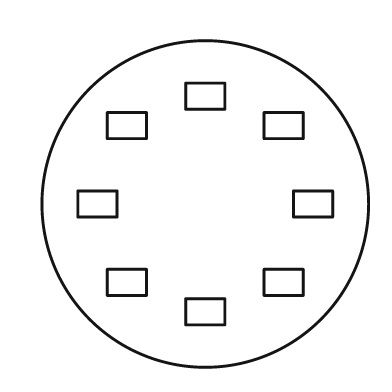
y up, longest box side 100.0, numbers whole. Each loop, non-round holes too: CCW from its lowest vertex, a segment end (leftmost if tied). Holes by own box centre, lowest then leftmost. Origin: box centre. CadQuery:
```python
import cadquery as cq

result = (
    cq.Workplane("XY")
    .moveTo(0.0, 0.0)
    .circle(50.0)
    .moveTo(-6.0, -37.0)
    .lineTo(6.0, -37.0)
    .lineTo(6.0, -29.0)
    .lineTo(-6.0, -29.0)
    .close()
    .moveTo(-30.0, -28.0)
    .lineTo(-18.0, -28.0)
    .lineTo(-18.0, -20.0)
    .lineTo(-30.0, -20.0)
    .close()
    .moveTo(18.0, -28.0)
    .lineTo(30.0, -28.0)
    .lineTo(30.0, -20.0)
    .lineTo(18.0, -20.0)
    .close()
    .moveTo(-39.0, -4.0)
    .lineTo(-27.0, -4.0)
    .lineTo(-27.0, 4.0)
    .lineTo(-39.0, 4.0)
    .close()
    .moveTo(27.0, -4.0)
    .lineTo(39.0, -4.0)
    .lineTo(39.0, 4.0)
    .lineTo(27.0, 4.0)
    .close()
    .moveTo(-30.0, 20.0)
    .lineTo(-18.0, 20.0)
    .lineTo(-18.0, 28.0)
    .lineTo(-30.0, 28.0)
    .close()
    .moveTo(18.0, 20.0)
    .lineTo(30.0, 20.0)
    .lineTo(30.0, 28.0)
    .lineTo(18.0, 28.0)
    .close()
    .moveTo(-6.0, 29.0)
    .lineTo(6.0, 29.0)
    .lineTo(6.0, 37.0)
    .lineTo(-6.0, 37.0)
    .close()
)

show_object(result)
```